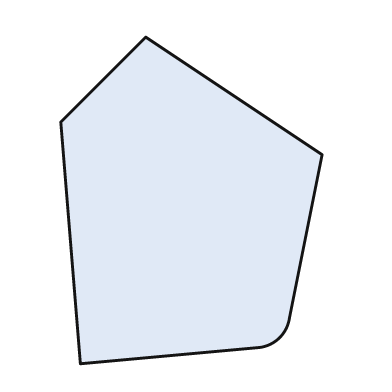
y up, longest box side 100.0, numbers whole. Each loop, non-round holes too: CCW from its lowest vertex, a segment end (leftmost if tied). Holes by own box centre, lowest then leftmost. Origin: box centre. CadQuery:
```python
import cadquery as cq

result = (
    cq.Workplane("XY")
    .moveTo(-34.0, -50.0)
    .lineTo(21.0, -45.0)
    .threePointArc((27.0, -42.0), (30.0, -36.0))
    .lineTo(40.0, 14.0)
    .lineTo(-14.0, 50.0)
    .lineTo(-40.0, 24.0)
    .close()
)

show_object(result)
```